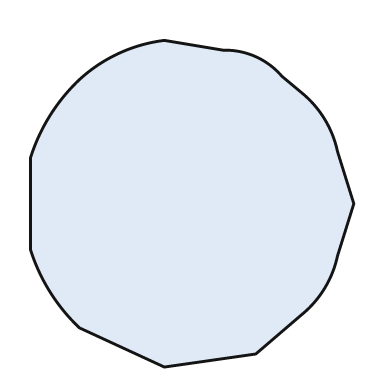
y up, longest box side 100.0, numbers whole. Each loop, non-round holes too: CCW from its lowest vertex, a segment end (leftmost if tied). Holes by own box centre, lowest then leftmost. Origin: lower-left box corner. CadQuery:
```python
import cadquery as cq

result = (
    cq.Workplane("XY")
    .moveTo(41.0, 0.0)
    .lineTo(69.0, 4.0)
    .lineTo(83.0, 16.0)
    .threePointArc((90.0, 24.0), (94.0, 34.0))
    .lineTo(99.0, 50.0)
    .lineTo(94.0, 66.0)
    .threePointArc((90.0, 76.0), (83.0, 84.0))
    .lineTo(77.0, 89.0)
    .threePointArc((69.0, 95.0), (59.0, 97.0))
    .lineTo(41.0, 100.0)
    .threePointArc((27.0, 96.0), (15.0, 88.0))
    .threePointArc((6.0, 77.0), (0.0, 64.0))
    .lineTo(0.0, 36.0)
    .threePointArc((6.0, 23.0), (15.0, 12.0))
    .close()
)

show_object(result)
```